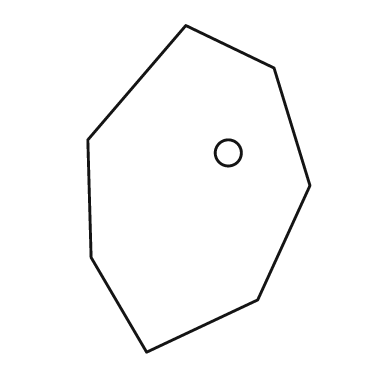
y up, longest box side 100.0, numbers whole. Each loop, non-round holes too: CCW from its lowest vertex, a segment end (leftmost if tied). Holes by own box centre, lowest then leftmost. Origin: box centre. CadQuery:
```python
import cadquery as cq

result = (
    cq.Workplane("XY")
    .moveTo(-16.0, -50.0)
    .lineTo(18.0, -34.0)
    .lineTo(34.0, 1.0)
    .lineTo(23.0, 37.0)
    .lineTo(-4.0, 50.0)
    .lineTo(-34.0, 15.0)
    .lineTo(-33.0, -21.0)
    .close()
    .moveTo(9.0, 11.0)
    .circle(4.0)
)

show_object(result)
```